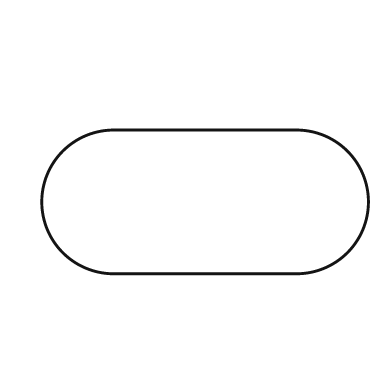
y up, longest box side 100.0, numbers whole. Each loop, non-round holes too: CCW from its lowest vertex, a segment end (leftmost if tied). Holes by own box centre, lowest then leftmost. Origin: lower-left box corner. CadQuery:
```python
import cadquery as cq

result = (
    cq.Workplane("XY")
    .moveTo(22.0, 0.0)
    .lineTo(78.0, 0.0)
    .threePointArc((100.0, 22.0), (78.0, 44.0))
    .lineTo(22.0, 44.0)
    .threePointArc((0.0, 22.0), (22.0, 0.0))
    .close()
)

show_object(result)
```